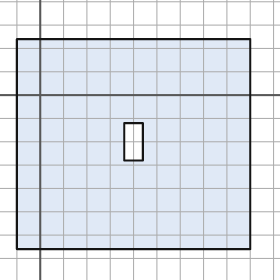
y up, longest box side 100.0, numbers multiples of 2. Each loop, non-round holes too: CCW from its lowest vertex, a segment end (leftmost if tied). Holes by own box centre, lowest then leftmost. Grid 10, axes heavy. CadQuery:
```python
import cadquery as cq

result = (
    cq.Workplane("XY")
    .moveTo(-10.0, -66.0)
    .lineTo(90.0, -66.0)
    .lineTo(90.0, 24.0)
    .lineTo(-10.0, 24.0)
    .close()
    .moveTo(36.0, -28.0)
    .lineTo(44.0, -28.0)
    .lineTo(44.0, -12.0)
    .lineTo(36.0, -12.0)
    .close()
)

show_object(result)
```